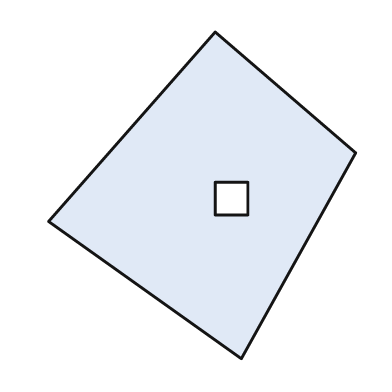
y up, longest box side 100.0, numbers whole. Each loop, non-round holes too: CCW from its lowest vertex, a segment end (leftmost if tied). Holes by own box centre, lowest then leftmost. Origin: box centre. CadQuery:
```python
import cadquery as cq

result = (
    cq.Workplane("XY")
    .moveTo(12.0, -50.0)
    .lineTo(47.0, 13.0)
    .lineTo(4.0, 50.0)
    .lineTo(-47.0, -8.0)
    .close()
    .moveTo(4.0, -6.0)
    .lineTo(14.0, -6.0)
    .lineTo(14.0, 4.0)
    .lineTo(4.0, 4.0)
    .close()
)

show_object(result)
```